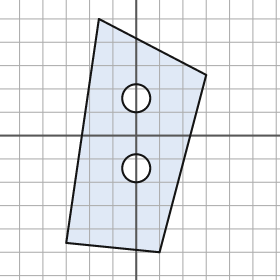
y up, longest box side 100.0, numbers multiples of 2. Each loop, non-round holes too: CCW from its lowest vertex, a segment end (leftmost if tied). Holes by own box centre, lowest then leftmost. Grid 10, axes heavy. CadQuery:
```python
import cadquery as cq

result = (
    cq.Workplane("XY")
    .moveTo(10.0, -50.0)
    .lineTo(30.0, 26.0)
    .lineTo(-16.0, 50.0)
    .lineTo(-30.0, -46.0)
    .close()
    .moveTo(0.0, -14.0)
    .circle(6.0)
    .moveTo(0.0, 16.0)
    .circle(6.0)
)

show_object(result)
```